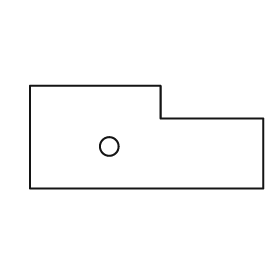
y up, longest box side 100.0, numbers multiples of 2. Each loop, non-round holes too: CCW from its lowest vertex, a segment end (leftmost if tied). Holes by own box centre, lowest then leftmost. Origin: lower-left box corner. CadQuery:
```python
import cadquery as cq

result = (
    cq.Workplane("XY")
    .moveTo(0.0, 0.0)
    .lineTo(100.0, 0.0)
    .lineTo(100.0, 30.0)
    .lineTo(56.0, 30.0)
    .lineTo(56.0, 44.0)
    .lineTo(0.0, 44.0)
    .close()
    .moveTo(34.0, 18.0)
    .circle(4.0)
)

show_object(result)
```